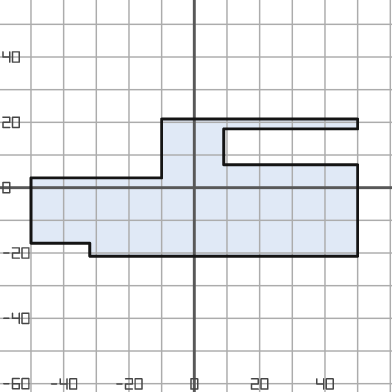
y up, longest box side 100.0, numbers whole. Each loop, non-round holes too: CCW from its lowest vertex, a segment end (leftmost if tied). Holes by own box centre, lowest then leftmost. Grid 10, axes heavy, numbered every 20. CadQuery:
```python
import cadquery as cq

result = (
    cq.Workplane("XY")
    .moveTo(-32.0, -21.0)
    .lineTo(50.0, -21.0)
    .lineTo(50.0, 7.0)
    .lineTo(9.0, 7.0)
    .lineTo(9.0, 18.0)
    .lineTo(50.0, 18.0)
    .lineTo(50.0, 21.0)
    .lineTo(-10.0, 21.0)
    .lineTo(-10.0, 3.0)
    .lineTo(-50.0, 3.0)
    .lineTo(-50.0, -17.0)
    .lineTo(-32.0, -17.0)
    .close()
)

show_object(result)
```